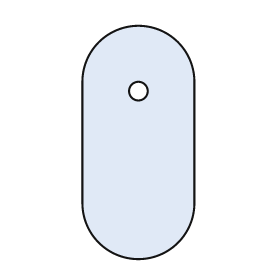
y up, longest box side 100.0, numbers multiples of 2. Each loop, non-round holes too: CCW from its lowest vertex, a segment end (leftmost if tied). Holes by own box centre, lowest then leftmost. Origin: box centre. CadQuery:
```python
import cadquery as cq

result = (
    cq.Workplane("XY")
    .moveTo(-24.0, -26.0)
    .threePointArc((0.0, -50.0), (24.0, -26.0))
    .lineTo(24.0, 26.0)
    .threePointArc((0.0, 50.0), (-24.0, 26.0))
    .close()
    .moveTo(0.0, 22.0)
    .circle(4.0)
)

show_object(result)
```